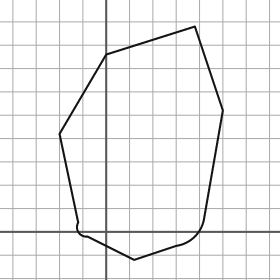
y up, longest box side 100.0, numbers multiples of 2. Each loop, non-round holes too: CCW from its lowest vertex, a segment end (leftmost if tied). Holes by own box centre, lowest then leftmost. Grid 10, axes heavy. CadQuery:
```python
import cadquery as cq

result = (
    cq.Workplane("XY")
    .moveTo(12.0, -12.0)
    .lineTo(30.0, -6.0)
    .threePointArc((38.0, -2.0), (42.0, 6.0))
    .lineTo(50.0, 52.0)
    .lineTo(38.0, 88.0)
    .lineTo(0.0, 76.0)
    .lineTo(-20.0, 42.0)
    .lineTo(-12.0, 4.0)
    .threePointArc((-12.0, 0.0), (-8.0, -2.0))
    .close()
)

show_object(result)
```